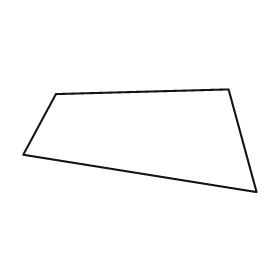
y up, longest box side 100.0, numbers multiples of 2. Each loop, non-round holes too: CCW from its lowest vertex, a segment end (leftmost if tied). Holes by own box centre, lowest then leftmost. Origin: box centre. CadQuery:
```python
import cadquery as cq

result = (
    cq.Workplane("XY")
    .moveTo(50.0, -22.0)
    .lineTo(38.0, 22.0)
    .lineTo(-36.0, 20.0)
    .lineTo(-50.0, -6.0)
    .close()
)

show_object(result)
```